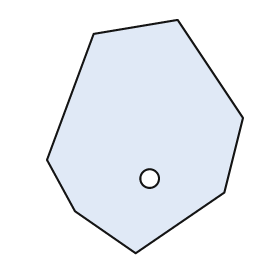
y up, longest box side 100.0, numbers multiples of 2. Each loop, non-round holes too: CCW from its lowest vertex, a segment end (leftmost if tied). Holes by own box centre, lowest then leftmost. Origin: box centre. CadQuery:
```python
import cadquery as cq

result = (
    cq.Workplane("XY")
    .moveTo(-4.0, -50.0)
    .lineTo(34.0, -24.0)
    .lineTo(42.0, 8.0)
    .lineTo(14.0, 50.0)
    .lineTo(-22.0, 44.0)
    .lineTo(-42.0, -10.0)
    .lineTo(-30.0, -32.0)
    .close()
    .moveTo(2.0, -18.0)
    .circle(4.0)
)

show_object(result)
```